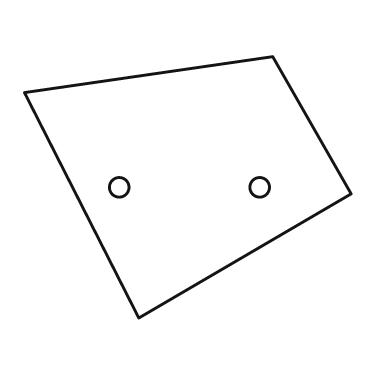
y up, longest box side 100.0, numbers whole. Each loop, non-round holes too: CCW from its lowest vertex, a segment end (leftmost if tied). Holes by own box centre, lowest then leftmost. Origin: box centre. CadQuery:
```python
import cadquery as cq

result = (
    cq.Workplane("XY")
    .moveTo(-15.0, -40.0)
    .lineTo(50.0, -2.0)
    .lineTo(26.0, 40.0)
    .lineTo(-50.0, 29.0)
    .close()
    .moveTo(-21.0, 0.0)
    .circle(3.0)
    .moveTo(22.0, 0.0)
    .circle(3.0)
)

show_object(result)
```